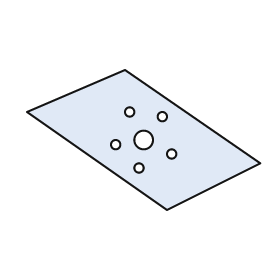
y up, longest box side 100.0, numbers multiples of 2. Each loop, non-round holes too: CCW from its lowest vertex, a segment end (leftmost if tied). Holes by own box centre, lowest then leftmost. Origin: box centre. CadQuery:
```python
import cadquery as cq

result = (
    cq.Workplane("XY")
    .moveTo(10.0, -30.0)
    .lineTo(50.0, -10.0)
    .lineTo(-8.0, 30.0)
    .lineTo(-50.0, 12.0)
    .close()
    .moveTo(-2.0, -12.0)
    .circle(2.0)
    .moveTo(12.0, -6.0)
    .circle(2.0)
    .moveTo(-12.0, -2.0)
    .circle(2.0)
    .moveTo(0.0, 0.0)
    .circle(4.0)
    .moveTo(8.0, 10.0)
    .circle(2.0)
    .moveTo(-6.0, 12.0)
    .circle(2.0)
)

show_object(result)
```